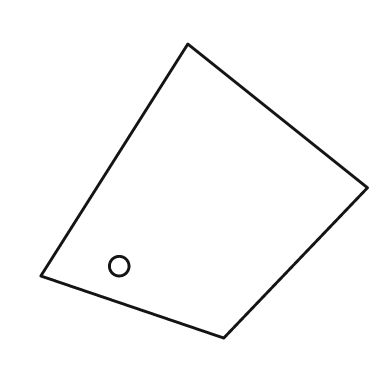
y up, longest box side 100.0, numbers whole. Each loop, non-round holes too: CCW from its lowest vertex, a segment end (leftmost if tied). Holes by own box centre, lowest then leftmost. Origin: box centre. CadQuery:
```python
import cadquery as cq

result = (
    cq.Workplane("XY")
    .moveTo(6.0, -45.0)
    .lineTo(50.0, 1.0)
    .lineTo(-5.0, 45.0)
    .lineTo(-50.0, -26.0)
    .close()
    .moveTo(-26.0, -23.0)
    .circle(3.0)
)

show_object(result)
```